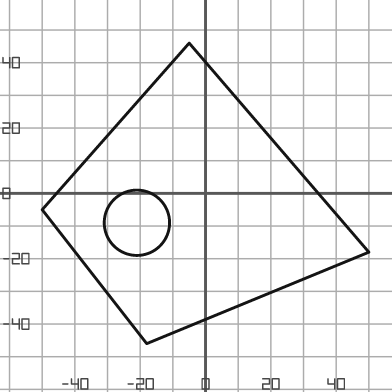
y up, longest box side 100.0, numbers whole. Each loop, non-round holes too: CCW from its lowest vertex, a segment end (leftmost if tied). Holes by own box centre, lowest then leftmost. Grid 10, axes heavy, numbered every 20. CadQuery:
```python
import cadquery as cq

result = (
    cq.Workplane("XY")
    .moveTo(-18.0, -46.0)
    .lineTo(50.0, -18.0)
    .lineTo(-5.0, 46.0)
    .lineTo(-50.0, -5.0)
    .close()
    .moveTo(-21.0, -9.0)
    .circle(10.0)
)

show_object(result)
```